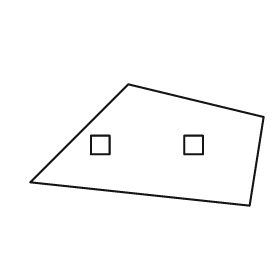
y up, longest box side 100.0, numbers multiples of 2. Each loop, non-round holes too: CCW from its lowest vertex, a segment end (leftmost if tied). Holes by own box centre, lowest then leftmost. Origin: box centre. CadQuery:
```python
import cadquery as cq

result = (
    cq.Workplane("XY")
    .moveTo(44.0, -26.0)
    .lineTo(50.0, 12.0)
    .lineTo(-8.0, 26.0)
    .lineTo(-50.0, -16.0)
    .close()
    .moveTo(-24.0, -4.0)
    .lineTo(-16.0, -4.0)
    .lineTo(-16.0, 4.0)
    .lineTo(-24.0, 4.0)
    .close()
    .moveTo(16.0, -4.0)
    .lineTo(24.0, -4.0)
    .lineTo(24.0, 4.0)
    .lineTo(16.0, 4.0)
    .close()
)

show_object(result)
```